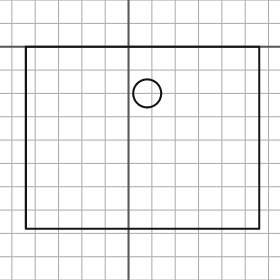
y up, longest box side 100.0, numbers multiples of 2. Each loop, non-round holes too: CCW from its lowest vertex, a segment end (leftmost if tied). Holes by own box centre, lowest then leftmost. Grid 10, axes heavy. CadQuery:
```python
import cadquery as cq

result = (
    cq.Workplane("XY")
    .moveTo(-44.0, -78.0)
    .lineTo(56.0, -78.0)
    .lineTo(56.0, 0.0)
    .lineTo(-44.0, 0.0)
    .close()
    .moveTo(8.0, -20.0)
    .circle(6.0)
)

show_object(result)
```